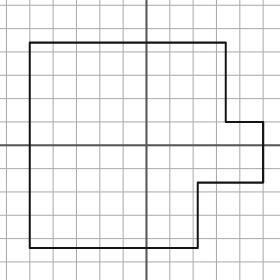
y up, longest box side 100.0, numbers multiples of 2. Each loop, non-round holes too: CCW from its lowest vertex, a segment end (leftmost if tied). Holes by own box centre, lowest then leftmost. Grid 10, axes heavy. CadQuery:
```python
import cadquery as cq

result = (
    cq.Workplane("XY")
    .moveTo(-50.0, -44.0)
    .lineTo(22.0, -44.0)
    .lineTo(22.0, -16.0)
    .lineTo(50.0, -16.0)
    .lineTo(50.0, 10.0)
    .lineTo(34.0, 10.0)
    .lineTo(34.0, 44.0)
    .lineTo(-50.0, 44.0)
    .close()
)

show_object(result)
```